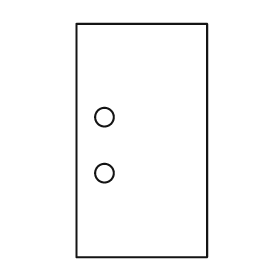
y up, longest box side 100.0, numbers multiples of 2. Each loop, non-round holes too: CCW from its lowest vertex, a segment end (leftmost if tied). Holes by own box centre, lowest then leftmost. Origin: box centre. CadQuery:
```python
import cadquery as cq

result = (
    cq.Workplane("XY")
    .moveTo(-28.0, -50.0)
    .lineTo(28.0, -50.0)
    .lineTo(28.0, 50.0)
    .lineTo(-28.0, 50.0)
    .close()
    .moveTo(-16.0, -14.0)
    .circle(4.0)
    .moveTo(-16.0, 10.0)
    .circle(4.0)
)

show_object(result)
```